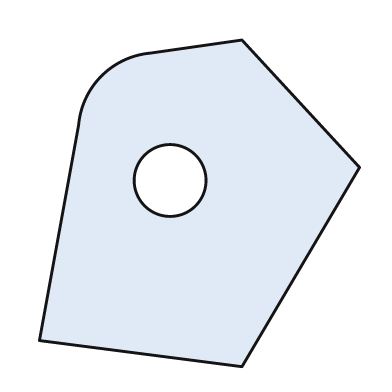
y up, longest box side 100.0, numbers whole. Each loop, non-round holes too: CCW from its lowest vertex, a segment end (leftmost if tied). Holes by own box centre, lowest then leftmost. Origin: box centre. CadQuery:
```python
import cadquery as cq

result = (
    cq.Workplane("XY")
    .moveTo(13.0, -50.0)
    .lineTo(49.0, 11.0)
    .lineTo(13.0, 50.0)
    .lineTo(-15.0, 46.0)
    .threePointArc((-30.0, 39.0), (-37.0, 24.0))
    .lineTo(-49.0, -42.0)
    .close()
    .moveTo(-9.0, 7.0)
    .circle(11.0)
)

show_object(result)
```